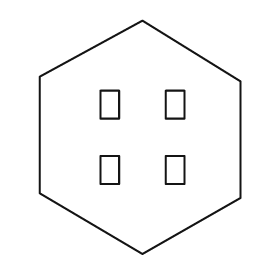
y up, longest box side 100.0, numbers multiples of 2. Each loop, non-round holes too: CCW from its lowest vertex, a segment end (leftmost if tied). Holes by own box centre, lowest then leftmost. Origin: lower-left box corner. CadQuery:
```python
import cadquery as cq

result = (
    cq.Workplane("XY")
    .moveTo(44.0, 0.0)
    .lineTo(86.0, 24.0)
    .lineTo(86.0, 74.0)
    .lineTo(44.0, 100.0)
    .lineTo(0.0, 76.0)
    .lineTo(0.0, 26.0)
    .close()
    .moveTo(26.0, 30.0)
    .lineTo(34.0, 30.0)
    .lineTo(34.0, 42.0)
    .lineTo(26.0, 42.0)
    .close()
    .moveTo(54.0, 30.0)
    .lineTo(62.0, 30.0)
    .lineTo(62.0, 42.0)
    .lineTo(54.0, 42.0)
    .close()
    .moveTo(26.0, 58.0)
    .lineTo(34.0, 58.0)
    .lineTo(34.0, 70.0)
    .lineTo(26.0, 70.0)
    .close()
    .moveTo(54.0, 58.0)
    .lineTo(62.0, 58.0)
    .lineTo(62.0, 70.0)
    .lineTo(54.0, 70.0)
    .close()
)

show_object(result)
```